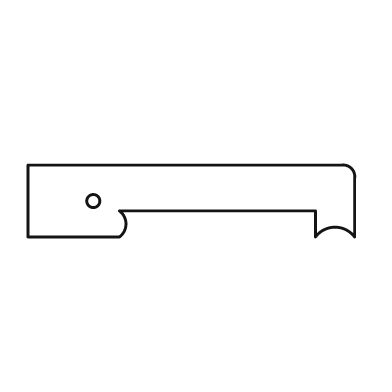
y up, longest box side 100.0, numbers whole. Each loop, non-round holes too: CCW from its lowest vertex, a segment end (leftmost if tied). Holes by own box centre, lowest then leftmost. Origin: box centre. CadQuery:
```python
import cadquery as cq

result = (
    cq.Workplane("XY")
    .moveTo(-50.0, -11.0)
    .lineTo(-22.0, -11.0)
    .threePointArc((-20.0, -7.0), (-22.0, -3.0))
    .lineTo(38.0, -3.0)
    .lineTo(38.0, -11.0)
    .threePointArc((44.0, -8.0), (50.0, -11.0))
    .lineTo(50.0, 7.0)
    .threePointArc((49.0, 10.0), (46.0, 11.0))
    .lineTo(-50.0, 11.0)
    .close()
    .moveTo(-30.0, 0.0)
    .circle(2.0)
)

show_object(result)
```